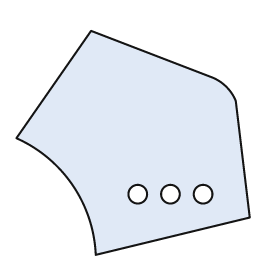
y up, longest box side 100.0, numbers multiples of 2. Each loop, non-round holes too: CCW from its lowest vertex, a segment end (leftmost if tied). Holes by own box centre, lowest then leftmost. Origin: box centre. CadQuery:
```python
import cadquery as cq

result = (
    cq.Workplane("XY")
    .moveTo(-16.0, -48.0)
    .lineTo(50.0, -32.0)
    .lineTo(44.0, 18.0)
    .threePointArc((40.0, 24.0), (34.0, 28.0))
    .lineTo(-18.0, 48.0)
    .lineTo(-50.0, 2.0)
    .threePointArc((-26.0, -18.0), (-16.0, -48.0))
    .close()
    .moveTo(2.0, -22.0)
    .circle(4.0)
    .moveTo(16.0, -22.0)
    .circle(4.0)
    .moveTo(30.0, -22.0)
    .circle(4.0)
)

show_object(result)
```